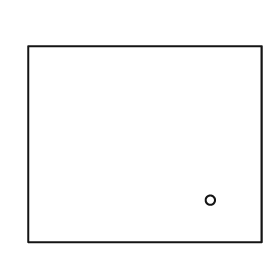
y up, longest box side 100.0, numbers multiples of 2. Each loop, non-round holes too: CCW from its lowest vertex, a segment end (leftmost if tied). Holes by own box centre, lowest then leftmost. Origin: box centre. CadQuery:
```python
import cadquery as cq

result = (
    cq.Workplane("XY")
    .moveTo(-50.0, -42.0)
    .lineTo(50.0, -42.0)
    .lineTo(50.0, 42.0)
    .lineTo(-50.0, 42.0)
    .close()
    .moveTo(28.0, -24.0)
    .circle(2.0)
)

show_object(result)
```